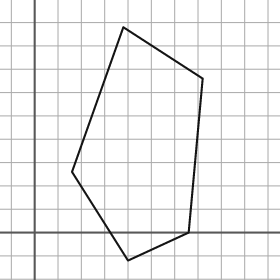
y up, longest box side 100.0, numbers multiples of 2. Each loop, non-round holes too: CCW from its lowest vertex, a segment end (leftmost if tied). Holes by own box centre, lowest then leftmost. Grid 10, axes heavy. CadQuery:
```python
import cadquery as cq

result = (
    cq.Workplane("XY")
    .moveTo(40.0, -12.0)
    .lineTo(66.0, 0.0)
    .lineTo(72.0, 66.0)
    .lineTo(38.0, 88.0)
    .lineTo(16.0, 26.0)
    .close()
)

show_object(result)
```